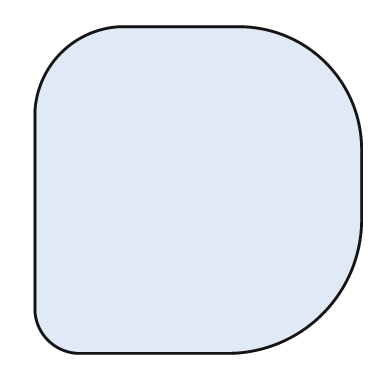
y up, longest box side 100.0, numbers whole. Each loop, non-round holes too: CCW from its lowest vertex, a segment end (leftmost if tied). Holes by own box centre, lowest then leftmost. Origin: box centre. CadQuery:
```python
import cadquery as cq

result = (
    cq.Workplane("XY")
    .moveTo(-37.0, -50.0)
    .lineTo(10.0, -50.0)
    .threePointArc((38.0, -38.0), (50.0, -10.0))
    .lineTo(50.0, 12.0)
    .threePointArc((39.0, 39.0), (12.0, 50.0))
    .lineTo(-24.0, 50.0)
    .threePointArc((-42.0, 42.0), (-50.0, 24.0))
    .lineTo(-50.0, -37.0)
    .threePointArc((-46.0, -46.0), (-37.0, -50.0))
    .close()
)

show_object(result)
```